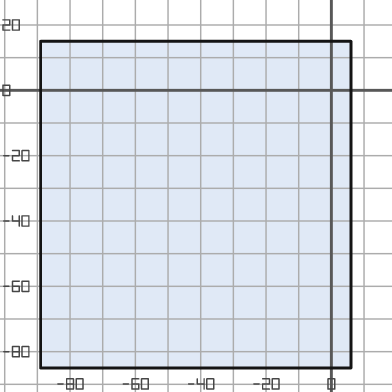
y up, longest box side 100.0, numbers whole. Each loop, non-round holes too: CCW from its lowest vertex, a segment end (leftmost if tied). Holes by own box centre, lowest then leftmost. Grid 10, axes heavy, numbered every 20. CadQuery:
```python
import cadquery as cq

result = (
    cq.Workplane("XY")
    .moveTo(-89.0, -85.0)
    .lineTo(6.0, -85.0)
    .lineTo(6.0, 15.0)
    .lineTo(-89.0, 15.0)
    .close()
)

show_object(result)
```